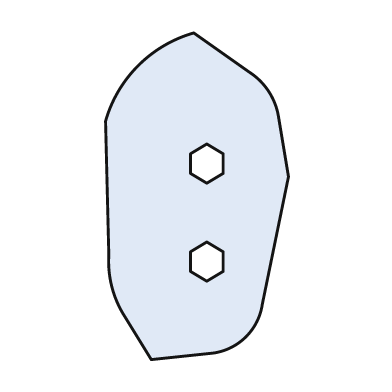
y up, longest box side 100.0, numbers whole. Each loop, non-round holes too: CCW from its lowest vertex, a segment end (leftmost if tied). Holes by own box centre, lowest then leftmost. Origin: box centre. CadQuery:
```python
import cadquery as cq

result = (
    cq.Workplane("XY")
    .moveTo(-14.0, -50.0)
    .lineTo(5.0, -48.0)
    .threePointArc((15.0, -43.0), (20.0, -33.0))
    .lineTo(28.0, 6.0)
    .lineTo(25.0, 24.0)
    .threePointArc((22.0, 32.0), (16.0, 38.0))
    .lineTo(-1.0, 50.0)
    .threePointArc((-18.0, 40.0), (-28.0, 23.0))
    .lineTo(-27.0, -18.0)
    .threePointArc((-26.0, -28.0), (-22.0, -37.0))
    .close()
    .moveTo(3.0, -26.0)
    .lineTo(8.0, -23.0)
    .lineTo(8.0, -17.0)
    .lineTo(3.0, -14.0)
    .lineTo(-2.0, -17.0)
    .lineTo(-2.0, -23.0)
    .close()
    .moveTo(3.0, 4.0)
    .lineTo(8.0, 7.0)
    .lineTo(8.0, 13.0)
    .lineTo(3.0, 16.0)
    .lineTo(-2.0, 13.0)
    .lineTo(-2.0, 7.0)
    .close()
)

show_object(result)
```